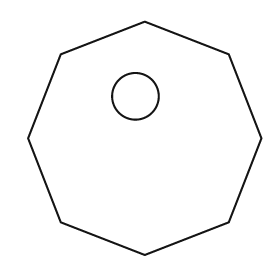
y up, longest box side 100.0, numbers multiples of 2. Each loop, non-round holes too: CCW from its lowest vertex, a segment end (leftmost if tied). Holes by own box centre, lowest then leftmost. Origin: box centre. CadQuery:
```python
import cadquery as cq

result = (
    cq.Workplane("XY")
    .moveTo(0.0, -50.0)
    .lineTo(36.0, -36.0)
    .lineTo(50.0, 0.0)
    .lineTo(36.0, 36.0)
    .lineTo(0.0, 50.0)
    .lineTo(-36.0, 36.0)
    .lineTo(-50.0, 0.0)
    .lineTo(-36.0, -36.0)
    .close()
    .moveTo(-4.0, 18.0)
    .circle(10.0)
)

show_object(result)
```